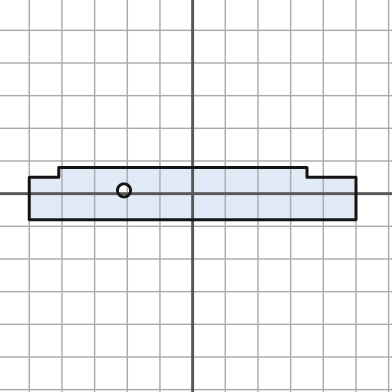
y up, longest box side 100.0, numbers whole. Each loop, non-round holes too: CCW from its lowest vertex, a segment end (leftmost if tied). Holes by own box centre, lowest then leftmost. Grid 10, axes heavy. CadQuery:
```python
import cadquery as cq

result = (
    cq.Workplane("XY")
    .moveTo(-50.0, -8.0)
    .lineTo(50.0, -8.0)
    .lineTo(50.0, 5.0)
    .lineTo(35.0, 5.0)
    .lineTo(35.0, 8.0)
    .lineTo(-41.0, 8.0)
    .lineTo(-41.0, 5.0)
    .lineTo(-50.0, 5.0)
    .close()
    .moveTo(-21.0, 1.0)
    .circle(2.0)
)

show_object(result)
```